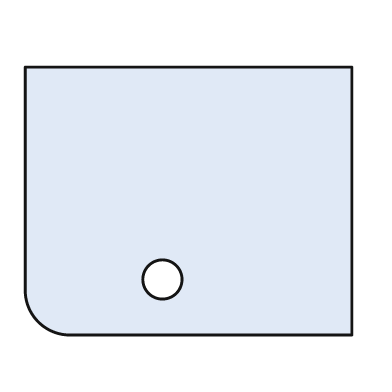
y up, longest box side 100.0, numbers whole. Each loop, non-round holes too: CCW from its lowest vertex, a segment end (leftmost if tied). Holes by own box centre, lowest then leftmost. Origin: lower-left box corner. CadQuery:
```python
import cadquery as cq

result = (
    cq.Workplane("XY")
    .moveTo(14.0, 0.0)
    .lineTo(100.0, 0.0)
    .lineTo(100.0, 82.0)
    .lineTo(0.0, 82.0)
    .lineTo(0.0, 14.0)
    .threePointArc((4.0, 4.0), (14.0, 0.0))
    .close()
    .moveTo(42.0, 17.0)
    .circle(6.0)
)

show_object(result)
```